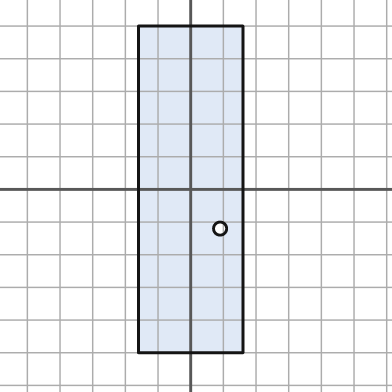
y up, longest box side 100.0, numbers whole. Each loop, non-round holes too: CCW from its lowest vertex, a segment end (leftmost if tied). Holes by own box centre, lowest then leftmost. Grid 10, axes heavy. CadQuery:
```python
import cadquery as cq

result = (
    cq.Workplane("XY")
    .moveTo(-16.0, -50.0)
    .lineTo(16.0, -50.0)
    .lineTo(16.0, 50.0)
    .lineTo(-16.0, 50.0)
    .close()
    .moveTo(9.0, -12.0)
    .circle(2.0)
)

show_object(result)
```